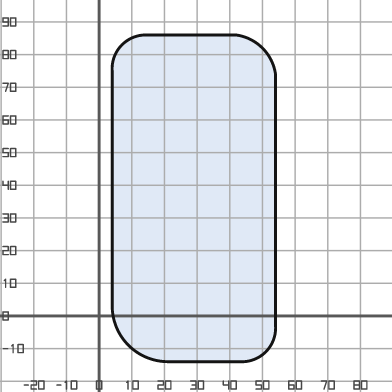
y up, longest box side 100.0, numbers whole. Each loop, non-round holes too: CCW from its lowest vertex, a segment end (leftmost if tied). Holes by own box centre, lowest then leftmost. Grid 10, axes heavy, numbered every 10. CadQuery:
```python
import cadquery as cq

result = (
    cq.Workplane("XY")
    .moveTo(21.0, -14.0)
    .lineTo(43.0, -14.0)
    .threePointArc((51.0, -11.0), (54.0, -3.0))
    .lineTo(54.0, 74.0)
    .threePointArc((50.0, 82.0), (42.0, 86.0))
    .lineTo(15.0, 86.0)
    .threePointArc((7.0, 83.0), (4.0, 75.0))
    .lineTo(4.0, 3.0)
    .threePointArc((9.0, -9.0), (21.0, -14.0))
    .close()
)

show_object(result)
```